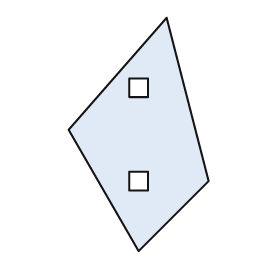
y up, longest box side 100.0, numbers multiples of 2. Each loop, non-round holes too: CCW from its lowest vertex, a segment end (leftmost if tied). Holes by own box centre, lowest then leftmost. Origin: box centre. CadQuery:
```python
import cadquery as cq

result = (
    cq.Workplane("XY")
    .moveTo(0.0, -50.0)
    .lineTo(30.0, -20.0)
    .lineTo(12.0, 50.0)
    .lineTo(-30.0, 2.0)
    .close()
    .moveTo(-4.0, -24.0)
    .lineTo(4.0, -24.0)
    .lineTo(4.0, -16.0)
    .lineTo(-4.0, -16.0)
    .close()
    .moveTo(-4.0, 16.0)
    .lineTo(4.0, 16.0)
    .lineTo(4.0, 24.0)
    .lineTo(-4.0, 24.0)
    .close()
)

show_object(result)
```